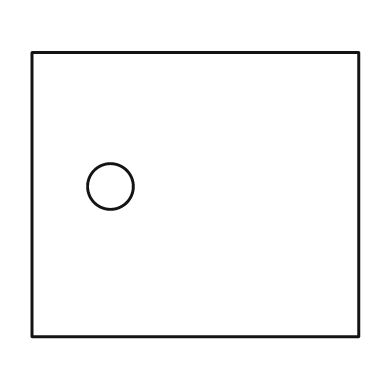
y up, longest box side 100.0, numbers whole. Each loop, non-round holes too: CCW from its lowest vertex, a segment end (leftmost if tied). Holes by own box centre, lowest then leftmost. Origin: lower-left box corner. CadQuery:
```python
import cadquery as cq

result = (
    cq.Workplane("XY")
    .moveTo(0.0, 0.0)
    .lineTo(100.0, 0.0)
    .lineTo(100.0, 87.0)
    .lineTo(0.0, 87.0)
    .close()
    .moveTo(24.0, 46.0)
    .circle(7.0)
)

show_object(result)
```